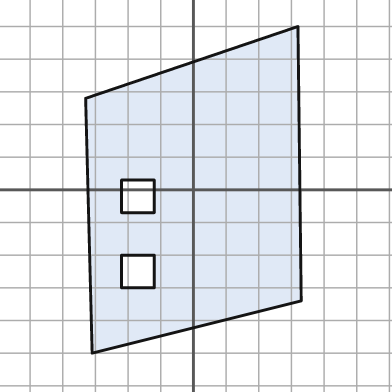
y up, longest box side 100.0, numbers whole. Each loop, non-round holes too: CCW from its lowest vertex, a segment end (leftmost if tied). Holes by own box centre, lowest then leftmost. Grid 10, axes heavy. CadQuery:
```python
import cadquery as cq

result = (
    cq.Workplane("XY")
    .moveTo(-31.0, -50.0)
    .lineTo(33.0, -34.0)
    .lineTo(32.0, 50.0)
    .lineTo(-33.0, 28.0)
    .close()
    .moveTo(-22.0, -30.0)
    .lineTo(-12.0, -30.0)
    .lineTo(-12.0, -20.0)
    .lineTo(-22.0, -20.0)
    .close()
    .moveTo(-22.0, -7.0)
    .lineTo(-12.0, -7.0)
    .lineTo(-12.0, 3.0)
    .lineTo(-22.0, 3.0)
    .close()
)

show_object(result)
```